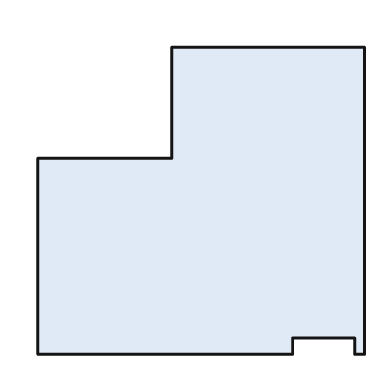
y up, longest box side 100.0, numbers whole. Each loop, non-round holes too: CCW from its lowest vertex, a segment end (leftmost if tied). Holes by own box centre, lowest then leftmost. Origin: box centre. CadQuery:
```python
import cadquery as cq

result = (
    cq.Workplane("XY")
    .moveTo(-50.0, -47.0)
    .lineTo(28.0, -47.0)
    .lineTo(28.0, -42.0)
    .lineTo(47.0, -42.0)
    .lineTo(47.0, -47.0)
    .lineTo(50.0, -47.0)
    .lineTo(50.0, 47.0)
    .lineTo(-9.0, 47.0)
    .lineTo(-9.0, 13.0)
    .lineTo(-50.0, 13.0)
    .close()
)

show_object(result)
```